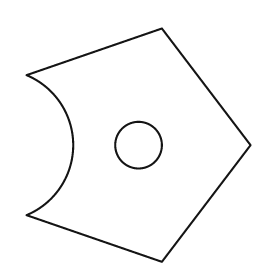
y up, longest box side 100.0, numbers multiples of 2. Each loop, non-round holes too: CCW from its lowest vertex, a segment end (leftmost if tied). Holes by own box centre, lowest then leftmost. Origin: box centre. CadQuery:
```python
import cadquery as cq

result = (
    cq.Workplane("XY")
    .moveTo(10.0, -50.0)
    .lineTo(48.0, 0.0)
    .lineTo(10.0, 50.0)
    .lineTo(-48.0, 30.0)
    .threePointArc((-28.0, 0.0), (-48.0, -30.0))
    .close()
    .moveTo(0.0, 0.0)
    .circle(10.0)
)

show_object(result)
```